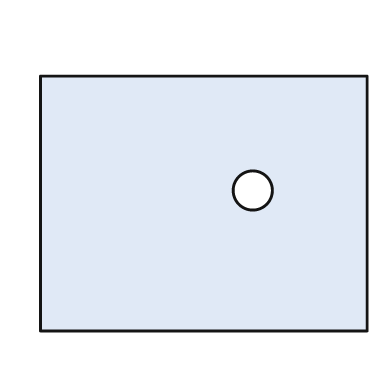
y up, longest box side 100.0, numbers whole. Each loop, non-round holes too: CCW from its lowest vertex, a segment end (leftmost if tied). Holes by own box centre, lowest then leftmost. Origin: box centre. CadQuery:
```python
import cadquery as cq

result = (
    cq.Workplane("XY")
    .moveTo(-50.0, -39.0)
    .lineTo(50.0, -39.0)
    .lineTo(50.0, 39.0)
    .lineTo(-50.0, 39.0)
    .close()
    .moveTo(15.0, 4.0)
    .circle(6.0)
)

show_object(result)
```